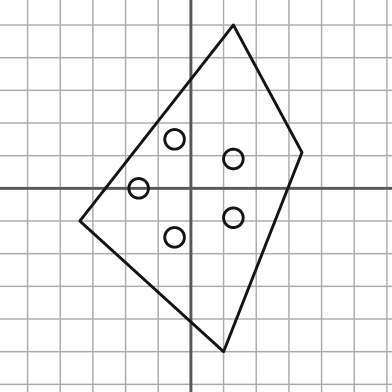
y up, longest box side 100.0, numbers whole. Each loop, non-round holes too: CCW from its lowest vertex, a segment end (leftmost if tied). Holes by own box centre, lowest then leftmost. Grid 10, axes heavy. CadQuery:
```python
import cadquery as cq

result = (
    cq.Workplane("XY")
    .moveTo(10.0, -50.0)
    .lineTo(34.0, 11.0)
    .lineTo(13.0, 50.0)
    .lineTo(-34.0, -10.0)
    .close()
    .moveTo(-5.0, -15.0)
    .circle(3.0)
    .moveTo(13.0, -9.0)
    .circle(3.0)
    .moveTo(-16.0, 0.0)
    .circle(3.0)
    .moveTo(13.0, 9.0)
    .circle(3.0)
    .moveTo(-5.0, 15.0)
    .circle(3.0)
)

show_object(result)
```